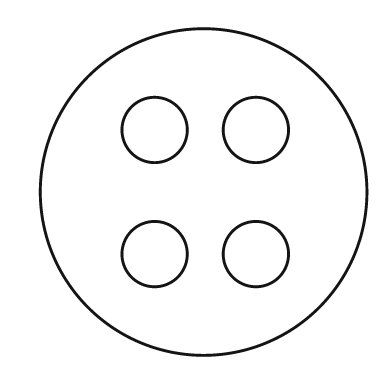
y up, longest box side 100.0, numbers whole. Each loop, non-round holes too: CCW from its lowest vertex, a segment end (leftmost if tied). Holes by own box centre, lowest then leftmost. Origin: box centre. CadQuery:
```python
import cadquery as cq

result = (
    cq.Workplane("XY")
    .moveTo(0.0, 0.0)
    .circle(50.0)
    .moveTo(-15.0, -19.0)
    .circle(10.0)
    .moveTo(16.0, -19.0)
    .circle(10.0)
    .moveTo(-15.0, 19.0)
    .circle(10.0)
    .moveTo(16.0, 19.0)
    .circle(10.0)
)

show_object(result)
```